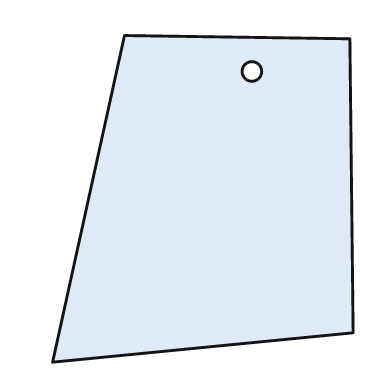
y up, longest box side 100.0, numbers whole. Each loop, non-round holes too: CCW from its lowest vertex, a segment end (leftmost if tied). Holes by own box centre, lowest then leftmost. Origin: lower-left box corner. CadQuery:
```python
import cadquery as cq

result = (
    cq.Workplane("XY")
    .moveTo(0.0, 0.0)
    .lineTo(92.0, 9.0)
    .lineTo(91.0, 99.0)
    .lineTo(22.0, 100.0)
    .close()
    .moveTo(61.0, 89.0)
    .circle(3.0)
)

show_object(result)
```